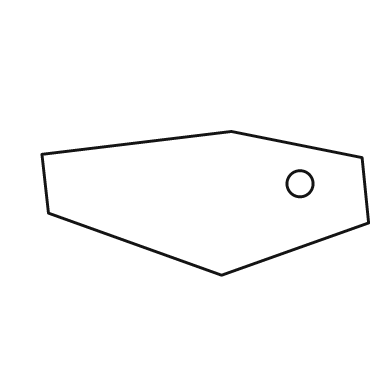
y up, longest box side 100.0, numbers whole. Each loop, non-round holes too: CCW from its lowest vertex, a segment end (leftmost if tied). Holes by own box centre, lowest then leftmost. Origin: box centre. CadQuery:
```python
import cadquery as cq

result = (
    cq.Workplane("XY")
    .moveTo(5.0, -22.0)
    .lineTo(50.0, -6.0)
    .lineTo(48.0, 14.0)
    .lineTo(8.0, 22.0)
    .lineTo(-50.0, 15.0)
    .lineTo(-48.0, -3.0)
    .close()
    .moveTo(29.0, 6.0)
    .circle(4.0)
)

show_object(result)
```